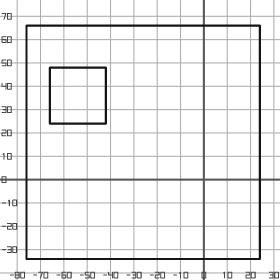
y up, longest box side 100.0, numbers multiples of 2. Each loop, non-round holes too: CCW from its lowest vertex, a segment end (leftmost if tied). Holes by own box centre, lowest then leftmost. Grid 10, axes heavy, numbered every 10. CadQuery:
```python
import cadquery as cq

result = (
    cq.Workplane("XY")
    .moveTo(-76.0, -34.0)
    .lineTo(24.0, -34.0)
    .lineTo(24.0, 66.0)
    .lineTo(-76.0, 66.0)
    .close()
    .moveTo(-66.0, 24.0)
    .lineTo(-42.0, 24.0)
    .lineTo(-42.0, 48.0)
    .lineTo(-66.0, 48.0)
    .close()
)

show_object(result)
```